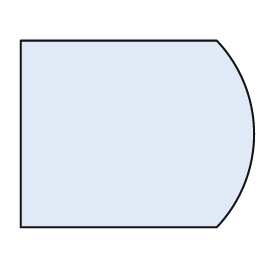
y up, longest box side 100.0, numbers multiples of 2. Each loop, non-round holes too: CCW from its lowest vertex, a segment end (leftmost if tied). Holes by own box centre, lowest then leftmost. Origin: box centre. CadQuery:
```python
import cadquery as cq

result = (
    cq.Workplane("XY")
    .moveTo(-50.0, -40.0)
    .lineTo(34.0, -40.0)
    .threePointArc((50.0, 0.0), (34.0, 40.0))
    .lineTo(-50.0, 40.0)
    .close()
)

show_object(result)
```